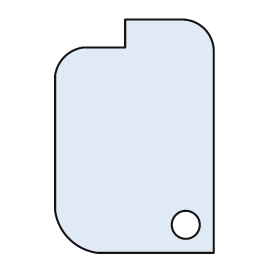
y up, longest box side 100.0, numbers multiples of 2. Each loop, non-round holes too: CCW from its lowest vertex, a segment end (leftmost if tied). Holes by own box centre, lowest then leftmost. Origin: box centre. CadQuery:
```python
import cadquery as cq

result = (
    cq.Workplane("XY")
    .moveTo(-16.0, -50.0)
    .lineTo(34.0, -50.0)
    .lineTo(34.0, 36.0)
    .threePointArc((30.0, 46.0), (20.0, 50.0))
    .lineTo(-4.0, 50.0)
    .lineTo(-4.0, 38.0)
    .lineTo(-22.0, 38.0)
    .threePointArc((-30.0, 34.0), (-34.0, 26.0))
    .lineTo(-34.0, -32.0)
    .threePointArc((-28.0, -44.0), (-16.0, -50.0))
    .close()
    .moveTo(22.0, -38.0)
    .circle(6.0)
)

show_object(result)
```